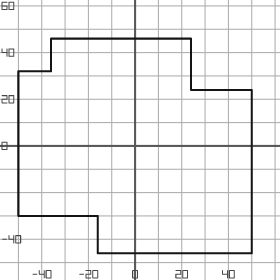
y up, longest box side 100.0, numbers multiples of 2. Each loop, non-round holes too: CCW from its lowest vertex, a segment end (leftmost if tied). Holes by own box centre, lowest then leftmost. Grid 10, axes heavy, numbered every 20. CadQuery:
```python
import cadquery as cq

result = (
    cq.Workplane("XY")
    .moveTo(-16.0, -46.0)
    .lineTo(50.0, -46.0)
    .lineTo(50.0, 24.0)
    .lineTo(24.0, 24.0)
    .lineTo(24.0, 46.0)
    .lineTo(-36.0, 46.0)
    .lineTo(-36.0, 32.0)
    .lineTo(-50.0, 32.0)
    .lineTo(-50.0, -30.0)
    .lineTo(-16.0, -30.0)
    .close()
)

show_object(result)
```